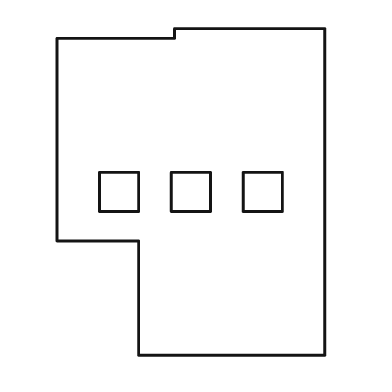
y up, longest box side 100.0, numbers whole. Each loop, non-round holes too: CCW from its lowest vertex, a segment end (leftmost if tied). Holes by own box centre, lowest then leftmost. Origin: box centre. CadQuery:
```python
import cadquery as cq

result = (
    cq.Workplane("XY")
    .moveTo(-16.0, -50.0)
    .lineTo(41.0, -50.0)
    .lineTo(41.0, 50.0)
    .lineTo(-5.0, 50.0)
    .lineTo(-5.0, 47.0)
    .lineTo(-41.0, 47.0)
    .lineTo(-41.0, -15.0)
    .lineTo(-16.0, -15.0)
    .close()
    .moveTo(-28.0, -6.0)
    .lineTo(-16.0, -6.0)
    .lineTo(-16.0, 6.0)
    .lineTo(-28.0, 6.0)
    .close()
    .moveTo(-6.0, -6.0)
    .lineTo(6.0, -6.0)
    .lineTo(6.0, 6.0)
    .lineTo(-6.0, 6.0)
    .close()
    .moveTo(16.0, -6.0)
    .lineTo(28.0, -6.0)
    .lineTo(28.0, 6.0)
    .lineTo(16.0, 6.0)
    .close()
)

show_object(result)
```